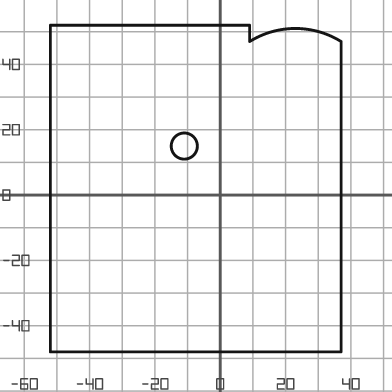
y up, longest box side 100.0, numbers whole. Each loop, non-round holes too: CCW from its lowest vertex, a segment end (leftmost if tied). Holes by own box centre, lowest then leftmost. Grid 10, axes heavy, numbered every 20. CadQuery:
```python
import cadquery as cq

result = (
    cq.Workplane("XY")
    .moveTo(-52.0, -48.0)
    .lineTo(37.0, -48.0)
    .lineTo(37.0, 47.0)
    .threePointArc((23.0, 51.0), (9.0, 47.0))
    .lineTo(9.0, 52.0)
    .lineTo(-52.0, 52.0)
    .close()
    .moveTo(-11.0, 15.0)
    .circle(4.0)
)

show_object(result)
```